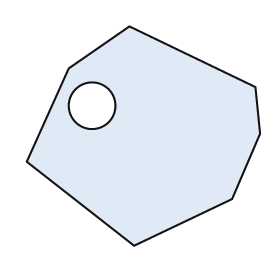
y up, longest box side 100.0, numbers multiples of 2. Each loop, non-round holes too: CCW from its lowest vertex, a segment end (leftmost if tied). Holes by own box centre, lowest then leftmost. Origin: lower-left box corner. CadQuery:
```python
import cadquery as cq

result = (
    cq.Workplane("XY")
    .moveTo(46.0, 0.0)
    .lineTo(88.0, 20.0)
    .lineTo(100.0, 48.0)
    .lineTo(98.0, 68.0)
    .lineTo(44.0, 94.0)
    .lineTo(18.0, 76.0)
    .lineTo(0.0, 36.0)
    .close()
    .moveTo(28.0, 60.0)
    .circle(10.0)
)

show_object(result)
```